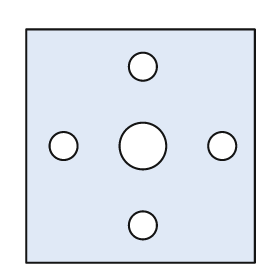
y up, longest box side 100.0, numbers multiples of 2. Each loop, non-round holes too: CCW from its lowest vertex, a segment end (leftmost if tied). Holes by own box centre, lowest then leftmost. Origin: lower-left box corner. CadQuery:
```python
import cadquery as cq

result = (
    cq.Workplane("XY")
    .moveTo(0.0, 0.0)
    .lineTo(98.0, 0.0)
    .lineTo(98.0, 100.0)
    .lineTo(0.0, 100.0)
    .close()
    .moveTo(50.0, 16.0)
    .circle(6.0)
    .moveTo(16.0, 50.0)
    .circle(6.0)
    .moveTo(50.0, 50.0)
    .circle(10.0)
    .moveTo(84.0, 50.0)
    .circle(6.0)
    .moveTo(50.0, 84.0)
    .circle(6.0)
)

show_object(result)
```